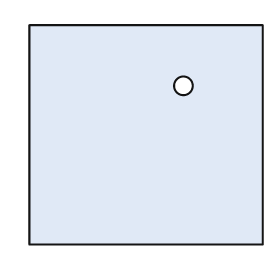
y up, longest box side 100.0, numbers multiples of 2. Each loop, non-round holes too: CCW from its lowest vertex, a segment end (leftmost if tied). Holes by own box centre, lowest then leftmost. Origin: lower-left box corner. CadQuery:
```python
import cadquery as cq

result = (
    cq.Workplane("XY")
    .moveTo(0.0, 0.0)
    .lineTo(100.0, 0.0)
    .lineTo(100.0, 94.0)
    .lineTo(0.0, 94.0)
    .close()
    .moveTo(66.0, 68.0)
    .circle(4.0)
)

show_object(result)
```